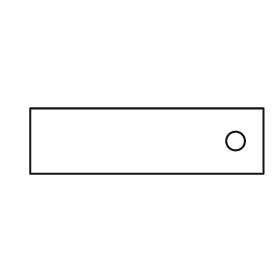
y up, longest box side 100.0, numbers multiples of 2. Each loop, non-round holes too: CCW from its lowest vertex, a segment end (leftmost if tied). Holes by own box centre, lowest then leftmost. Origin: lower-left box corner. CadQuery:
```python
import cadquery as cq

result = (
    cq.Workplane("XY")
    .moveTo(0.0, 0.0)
    .lineTo(100.0, 0.0)
    .lineTo(100.0, 28.0)
    .lineTo(0.0, 28.0)
    .close()
    .moveTo(88.0, 14.0)
    .circle(4.0)
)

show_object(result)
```